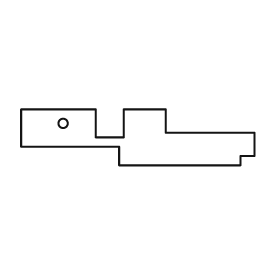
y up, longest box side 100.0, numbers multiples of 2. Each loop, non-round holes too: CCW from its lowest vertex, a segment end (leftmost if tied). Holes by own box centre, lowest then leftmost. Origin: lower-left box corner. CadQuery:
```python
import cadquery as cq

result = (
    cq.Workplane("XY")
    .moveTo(42.0, 0.0)
    .lineTo(94.0, 0.0)
    .lineTo(94.0, 4.0)
    .lineTo(100.0, 4.0)
    .lineTo(100.0, 14.0)
    .lineTo(62.0, 14.0)
    .lineTo(62.0, 24.0)
    .lineTo(44.0, 24.0)
    .lineTo(44.0, 12.0)
    .lineTo(32.0, 12.0)
    .lineTo(32.0, 24.0)
    .lineTo(0.0, 24.0)
    .lineTo(0.0, 8.0)
    .lineTo(42.0, 8.0)
    .close()
    .moveTo(18.0, 18.0)
    .circle(2.0)
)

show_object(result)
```